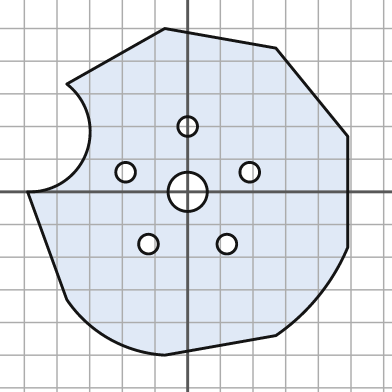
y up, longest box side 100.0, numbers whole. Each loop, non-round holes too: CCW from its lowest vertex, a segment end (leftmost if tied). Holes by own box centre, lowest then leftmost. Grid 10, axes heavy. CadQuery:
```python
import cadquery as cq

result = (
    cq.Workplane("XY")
    .moveTo(-7.0, -50.0)
    .lineTo(27.0, -44.0)
    .threePointArc((40.0, -32.0), (49.0, -17.0))
    .lineTo(49.0, 17.0)
    .lineTo(27.0, 44.0)
    .lineTo(-7.0, 50.0)
    .lineTo(-37.0, 33.0)
    .threePointArc((-31.0, 12.0), (-49.0, 0.0))
    .lineTo(-37.0, -33.0)
    .threePointArc((-24.0, -45.0), (-7.0, -50.0))
    .close()
    .moveTo(-12.0, -16.0)
    .circle(3.0)
    .moveTo(12.0, -16.0)
    .circle(3.0)
    .moveTo(0.0, 0.0)
    .circle(6.0)
    .moveTo(-19.0, 6.0)
    .circle(3.0)
    .moveTo(19.0, 6.0)
    .circle(3.0)
    .moveTo(0.0, 20.0)
    .circle(3.0)
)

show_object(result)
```